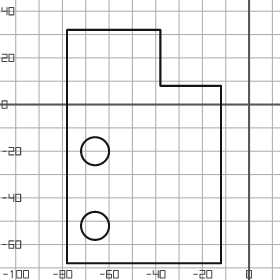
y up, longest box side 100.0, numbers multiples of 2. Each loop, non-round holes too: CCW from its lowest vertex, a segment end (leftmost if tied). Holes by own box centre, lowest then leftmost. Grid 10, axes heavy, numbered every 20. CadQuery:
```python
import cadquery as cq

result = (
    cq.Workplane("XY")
    .moveTo(-78.0, -68.0)
    .lineTo(-12.0, -68.0)
    .lineTo(-12.0, 8.0)
    .lineTo(-38.0, 8.0)
    .lineTo(-38.0, 32.0)
    .lineTo(-78.0, 32.0)
    .close()
    .moveTo(-66.0, -52.0)
    .circle(6.0)
    .moveTo(-66.0, -20.0)
    .circle(6.0)
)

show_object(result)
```